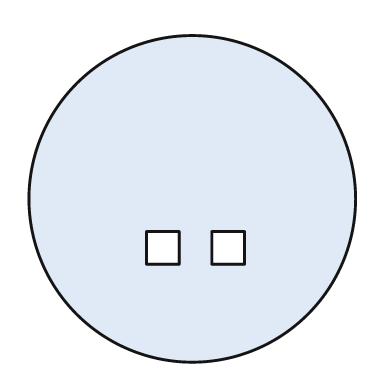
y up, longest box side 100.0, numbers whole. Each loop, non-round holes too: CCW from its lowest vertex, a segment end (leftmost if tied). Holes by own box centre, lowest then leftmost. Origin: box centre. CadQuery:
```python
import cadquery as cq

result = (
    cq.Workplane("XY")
    .moveTo(0.0, 0.0)
    .circle(50.0)
    .moveTo(-14.0, -20.0)
    .lineTo(-4.0, -20.0)
    .lineTo(-4.0, -10.0)
    .lineTo(-14.0, -10.0)
    .close()
    .moveTo(6.0, -20.0)
    .lineTo(16.0, -20.0)
    .lineTo(16.0, -10.0)
    .lineTo(6.0, -10.0)
    .close()
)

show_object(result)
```